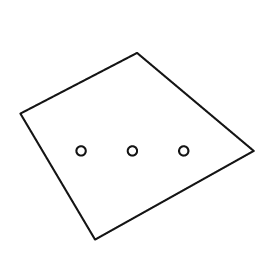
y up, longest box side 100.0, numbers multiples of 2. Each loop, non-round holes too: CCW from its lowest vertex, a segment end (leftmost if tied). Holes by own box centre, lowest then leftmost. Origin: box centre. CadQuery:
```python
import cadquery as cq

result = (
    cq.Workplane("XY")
    .moveTo(-18.0, -40.0)
    .lineTo(50.0, -2.0)
    .lineTo(0.0, 40.0)
    .lineTo(-50.0, 14.0)
    .close()
    .moveTo(-24.0, -2.0)
    .circle(2.0)
    .moveTo(-2.0, -2.0)
    .circle(2.0)
    .moveTo(20.0, -2.0)
    .circle(2.0)
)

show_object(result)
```